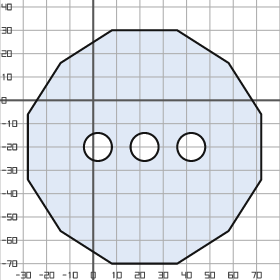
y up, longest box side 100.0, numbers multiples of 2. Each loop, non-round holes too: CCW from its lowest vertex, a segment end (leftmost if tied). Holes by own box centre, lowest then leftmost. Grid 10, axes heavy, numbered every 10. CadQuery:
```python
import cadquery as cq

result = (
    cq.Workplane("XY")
    .moveTo(8.0, -70.0)
    .lineTo(36.0, -70.0)
    .lineTo(58.0, -56.0)
    .lineTo(72.0, -34.0)
    .lineTo(72.0, -6.0)
    .lineTo(58.0, 16.0)
    .lineTo(36.0, 30.0)
    .lineTo(8.0, 30.0)
    .lineTo(-14.0, 16.0)
    .lineTo(-28.0, -6.0)
    .lineTo(-28.0, -34.0)
    .lineTo(-14.0, -56.0)
    .close()
    .moveTo(2.0, -20.0)
    .circle(6.0)
    .moveTo(22.0, -20.0)
    .circle(6.0)
    .moveTo(42.0, -20.0)
    .circle(6.0)
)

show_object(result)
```